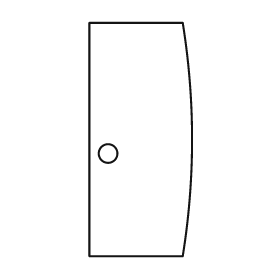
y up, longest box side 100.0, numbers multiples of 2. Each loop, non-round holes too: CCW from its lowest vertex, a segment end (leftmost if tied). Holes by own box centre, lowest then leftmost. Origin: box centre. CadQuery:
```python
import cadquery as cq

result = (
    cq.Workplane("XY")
    .moveTo(-22.0, -50.0)
    .lineTo(18.0, -50.0)
    .threePointArc((22.0, 0.0), (18.0, 50.0))
    .lineTo(-22.0, 50.0)
    .close()
    .moveTo(-14.0, -6.0)
    .circle(4.0)
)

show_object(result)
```